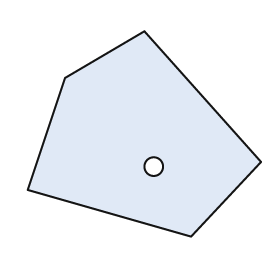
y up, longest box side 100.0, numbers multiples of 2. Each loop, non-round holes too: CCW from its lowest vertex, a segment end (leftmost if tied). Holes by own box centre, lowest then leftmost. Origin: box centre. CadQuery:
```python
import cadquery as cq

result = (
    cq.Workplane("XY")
    .moveTo(20.0, -44.0)
    .lineTo(50.0, -12.0)
    .lineTo(0.0, 44.0)
    .lineTo(-34.0, 24.0)
    .lineTo(-50.0, -24.0)
    .close()
    .moveTo(4.0, -14.0)
    .circle(4.0)
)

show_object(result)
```